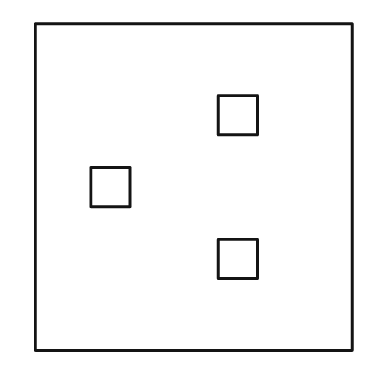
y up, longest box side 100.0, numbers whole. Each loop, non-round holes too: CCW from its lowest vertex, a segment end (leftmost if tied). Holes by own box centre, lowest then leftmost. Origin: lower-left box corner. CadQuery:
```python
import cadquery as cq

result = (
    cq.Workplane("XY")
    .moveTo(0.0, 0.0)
    .lineTo(97.0, 0.0)
    .lineTo(97.0, 100.0)
    .lineTo(0.0, 100.0)
    .close()
    .moveTo(56.0, 22.0)
    .lineTo(68.0, 22.0)
    .lineTo(68.0, 34.0)
    .lineTo(56.0, 34.0)
    .close()
    .moveTo(17.0, 44.0)
    .lineTo(29.0, 44.0)
    .lineTo(29.0, 56.0)
    .lineTo(17.0, 56.0)
    .close()
    .moveTo(56.0, 66.0)
    .lineTo(68.0, 66.0)
    .lineTo(68.0, 78.0)
    .lineTo(56.0, 78.0)
    .close()
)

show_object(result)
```